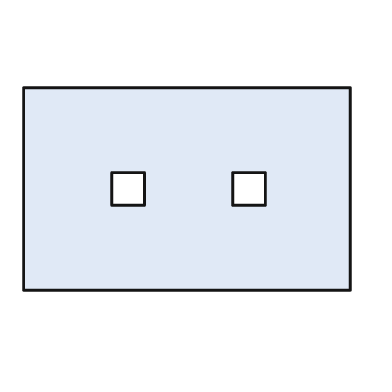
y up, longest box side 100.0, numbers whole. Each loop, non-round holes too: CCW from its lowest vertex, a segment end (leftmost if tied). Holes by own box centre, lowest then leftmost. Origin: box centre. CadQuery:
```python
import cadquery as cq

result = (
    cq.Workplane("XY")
    .moveTo(-50.0, -31.0)
    .lineTo(50.0, -31.0)
    .lineTo(50.0, 31.0)
    .lineTo(-50.0, 31.0)
    .close()
    .moveTo(-23.0, -5.0)
    .lineTo(-13.0, -5.0)
    .lineTo(-13.0, 5.0)
    .lineTo(-23.0, 5.0)
    .close()
    .moveTo(14.0, -5.0)
    .lineTo(24.0, -5.0)
    .lineTo(24.0, 5.0)
    .lineTo(14.0, 5.0)
    .close()
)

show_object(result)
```